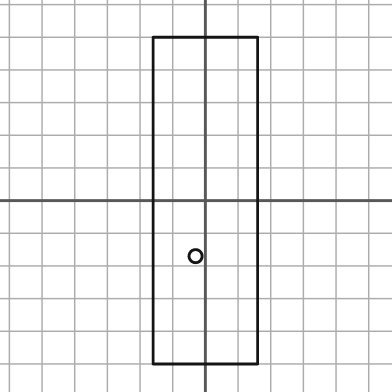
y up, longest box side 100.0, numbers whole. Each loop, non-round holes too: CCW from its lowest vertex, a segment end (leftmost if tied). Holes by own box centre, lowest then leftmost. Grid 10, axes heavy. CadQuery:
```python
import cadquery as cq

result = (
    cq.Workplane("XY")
    .moveTo(-16.0, -50.0)
    .lineTo(16.0, -50.0)
    .lineTo(16.0, 50.0)
    .lineTo(-16.0, 50.0)
    .close()
    .moveTo(-3.0, -17.0)
    .circle(2.0)
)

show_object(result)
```